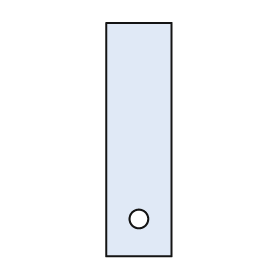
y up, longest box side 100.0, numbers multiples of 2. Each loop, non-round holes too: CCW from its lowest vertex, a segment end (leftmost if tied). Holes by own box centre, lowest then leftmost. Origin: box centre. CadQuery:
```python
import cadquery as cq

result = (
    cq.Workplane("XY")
    .moveTo(-14.0, -50.0)
    .lineTo(14.0, -50.0)
    .lineTo(14.0, 50.0)
    .lineTo(-14.0, 50.0)
    .close()
    .moveTo(0.0, -34.0)
    .circle(4.0)
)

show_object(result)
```